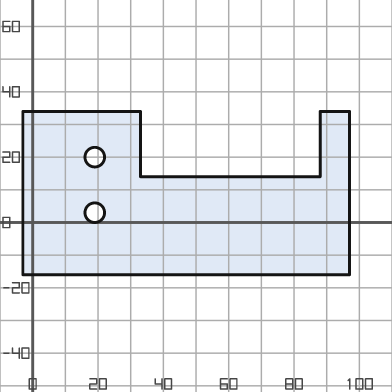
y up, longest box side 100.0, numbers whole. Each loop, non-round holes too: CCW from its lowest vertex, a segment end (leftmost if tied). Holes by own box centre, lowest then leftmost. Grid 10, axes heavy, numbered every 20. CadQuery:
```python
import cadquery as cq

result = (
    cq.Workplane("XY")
    .moveTo(-3.0, -16.0)
    .lineTo(97.0, -16.0)
    .lineTo(97.0, 34.0)
    .lineTo(88.0, 34.0)
    .lineTo(88.0, 14.0)
    .lineTo(33.0, 14.0)
    .lineTo(33.0, 34.0)
    .lineTo(-3.0, 34.0)
    .close()
    .moveTo(19.0, 3.0)
    .circle(3.0)
    .moveTo(19.0, 20.0)
    .circle(3.0)
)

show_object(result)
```